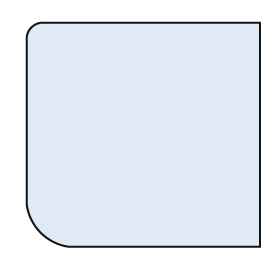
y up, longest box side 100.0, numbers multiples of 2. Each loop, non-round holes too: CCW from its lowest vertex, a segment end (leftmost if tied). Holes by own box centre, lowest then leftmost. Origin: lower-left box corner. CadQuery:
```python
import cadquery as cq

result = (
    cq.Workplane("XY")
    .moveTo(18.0, 0.0)
    .lineTo(100.0, 0.0)
    .lineTo(100.0, 96.0)
    .lineTo(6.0, 96.0)
    .threePointArc((2.0, 94.0), (0.0, 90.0))
    .lineTo(0.0, 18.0)
    .threePointArc((6.0, 6.0), (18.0, 0.0))
    .close()
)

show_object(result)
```